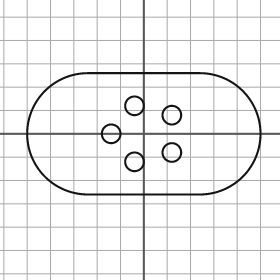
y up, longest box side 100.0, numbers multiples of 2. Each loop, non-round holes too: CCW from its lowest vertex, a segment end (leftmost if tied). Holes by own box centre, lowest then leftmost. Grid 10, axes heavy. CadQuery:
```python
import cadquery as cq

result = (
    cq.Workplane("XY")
    .moveTo(-24.0, -26.0)
    .lineTo(24.0, -26.0)
    .threePointArc((50.0, 0.0), (24.0, 26.0))
    .lineTo(-24.0, 26.0)
    .threePointArc((-50.0, 0.0), (-24.0, -26.0))
    .close()
    .moveTo(-4.0, -12.0)
    .circle(4.0)
    .moveTo(12.0, -8.0)
    .circle(4.0)
    .moveTo(-14.0, 0.0)
    .circle(4.0)
    .moveTo(12.0, 8.0)
    .circle(4.0)
    .moveTo(-4.0, 12.0)
    .circle(4.0)
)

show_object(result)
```